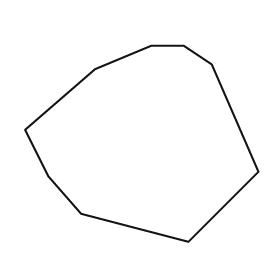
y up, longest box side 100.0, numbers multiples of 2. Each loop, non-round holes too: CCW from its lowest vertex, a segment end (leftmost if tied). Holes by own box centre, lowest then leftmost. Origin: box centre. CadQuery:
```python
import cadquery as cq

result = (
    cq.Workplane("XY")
    .moveTo(20.0, -42.0)
    .lineTo(50.0, -12.0)
    .lineTo(30.0, 34.0)
    .lineTo(18.0, 42.0)
    .lineTo(4.0, 42.0)
    .lineTo(-20.0, 32.0)
    .lineTo(-50.0, 6.0)
    .lineTo(-40.0, -14.0)
    .lineTo(-26.0, -30.0)
    .close()
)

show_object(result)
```